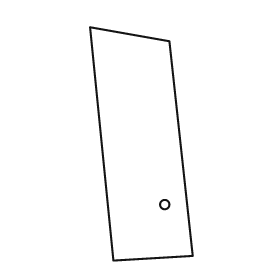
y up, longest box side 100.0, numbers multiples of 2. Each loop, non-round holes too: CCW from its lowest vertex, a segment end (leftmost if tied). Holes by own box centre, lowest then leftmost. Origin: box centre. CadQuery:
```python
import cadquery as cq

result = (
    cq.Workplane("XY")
    .moveTo(-12.0, -50.0)
    .lineTo(22.0, -48.0)
    .lineTo(12.0, 44.0)
    .lineTo(-22.0, 50.0)
    .close()
    .moveTo(10.0, -26.0)
    .circle(2.0)
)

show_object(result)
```